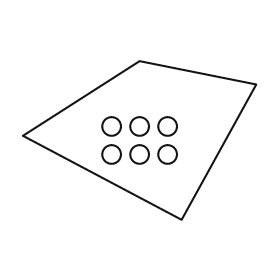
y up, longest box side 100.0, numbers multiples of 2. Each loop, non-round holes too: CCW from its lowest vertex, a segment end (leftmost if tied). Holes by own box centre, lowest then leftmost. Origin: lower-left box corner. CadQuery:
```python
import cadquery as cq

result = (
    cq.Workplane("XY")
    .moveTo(68.0, 0.0)
    .lineTo(100.0, 58.0)
    .lineTo(50.0, 68.0)
    .lineTo(0.0, 36.0)
    .close()
    .moveTo(38.0, 28.0)
    .circle(4.0)
    .moveTo(50.0, 28.0)
    .circle(4.0)
    .moveTo(62.0, 28.0)
    .circle(4.0)
    .moveTo(38.0, 40.0)
    .circle(4.0)
    .moveTo(50.0, 40.0)
    .circle(4.0)
    .moveTo(62.0, 40.0)
    .circle(4.0)
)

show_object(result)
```